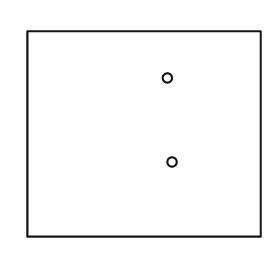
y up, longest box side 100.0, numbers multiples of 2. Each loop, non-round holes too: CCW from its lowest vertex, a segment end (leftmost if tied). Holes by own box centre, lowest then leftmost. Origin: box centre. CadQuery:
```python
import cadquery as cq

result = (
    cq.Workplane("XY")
    .moveTo(-50.0, -44.0)
    .lineTo(50.0, -44.0)
    .lineTo(50.0, 44.0)
    .lineTo(-50.0, 44.0)
    .close()
    .moveTo(12.0, -12.0)
    .circle(2.0)
    .moveTo(10.0, 24.0)
    .circle(2.0)
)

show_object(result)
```